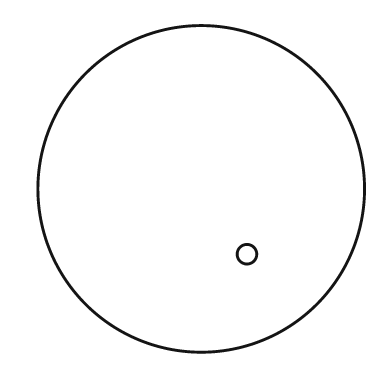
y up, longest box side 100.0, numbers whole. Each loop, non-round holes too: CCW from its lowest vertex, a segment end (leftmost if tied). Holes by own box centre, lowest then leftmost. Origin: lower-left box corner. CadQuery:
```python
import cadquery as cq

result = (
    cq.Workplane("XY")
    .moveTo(50.0, 50.0)
    .circle(50.0)
    .moveTo(64.0, 30.0)
    .circle(3.0)
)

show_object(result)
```